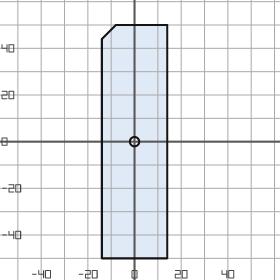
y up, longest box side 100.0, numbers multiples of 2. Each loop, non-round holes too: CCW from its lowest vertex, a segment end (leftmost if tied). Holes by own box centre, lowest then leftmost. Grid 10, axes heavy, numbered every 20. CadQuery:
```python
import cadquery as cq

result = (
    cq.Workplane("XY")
    .moveTo(-14.0, -50.0)
    .lineTo(14.0, -50.0)
    .lineTo(14.0, 50.0)
    .lineTo(-8.0, 50.0)
    .lineTo(-14.0, 44.0)
    .close()
    .moveTo(0.0, 0.0)
    .circle(2.0)
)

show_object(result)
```